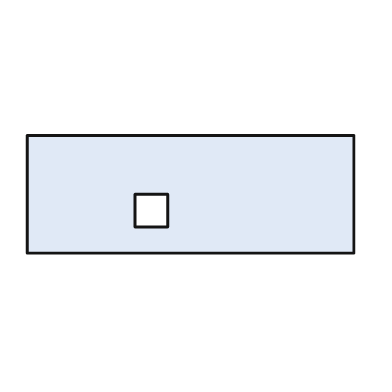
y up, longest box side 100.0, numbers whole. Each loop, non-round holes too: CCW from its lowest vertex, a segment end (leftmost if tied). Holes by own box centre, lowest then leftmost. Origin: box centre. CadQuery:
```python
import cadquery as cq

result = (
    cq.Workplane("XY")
    .moveTo(-50.0, -18.0)
    .lineTo(50.0, -18.0)
    .lineTo(50.0, 18.0)
    .lineTo(-50.0, 18.0)
    .close()
    .moveTo(-17.0, -10.0)
    .lineTo(-7.0, -10.0)
    .lineTo(-7.0, 0.0)
    .lineTo(-17.0, 0.0)
    .close()
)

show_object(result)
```